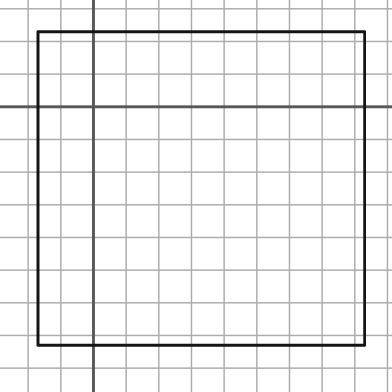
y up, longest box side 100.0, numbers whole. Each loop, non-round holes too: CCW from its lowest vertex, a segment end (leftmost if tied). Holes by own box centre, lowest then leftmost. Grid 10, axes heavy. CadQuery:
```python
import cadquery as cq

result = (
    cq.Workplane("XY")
    .moveTo(-17.0, -73.0)
    .lineTo(83.0, -73.0)
    .lineTo(83.0, 23.0)
    .lineTo(-17.0, 23.0)
    .close()
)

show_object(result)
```